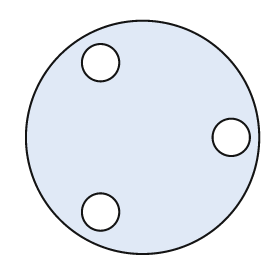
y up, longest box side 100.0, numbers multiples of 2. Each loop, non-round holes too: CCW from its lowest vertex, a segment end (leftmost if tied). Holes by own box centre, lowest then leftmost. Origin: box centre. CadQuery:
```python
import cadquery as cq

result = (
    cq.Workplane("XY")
    .moveTo(0.0, 0.0)
    .circle(50.0)
    .moveTo(-18.0, -32.0)
    .circle(8.0)
    .moveTo(38.0, 0.0)
    .circle(8.0)
    .moveTo(-18.0, 32.0)
    .circle(8.0)
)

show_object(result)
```